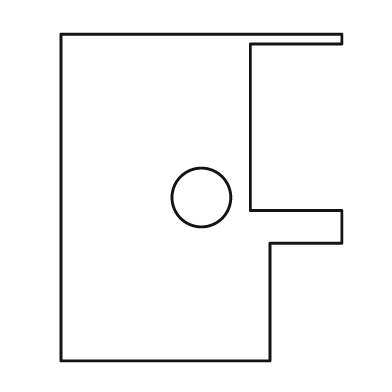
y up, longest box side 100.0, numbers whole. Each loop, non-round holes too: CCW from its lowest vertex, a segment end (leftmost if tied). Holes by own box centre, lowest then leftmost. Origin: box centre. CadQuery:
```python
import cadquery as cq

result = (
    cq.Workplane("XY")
    .moveTo(-43.0, -50.0)
    .lineTo(21.0, -50.0)
    .lineTo(21.0, -14.0)
    .lineTo(43.0, -14.0)
    .lineTo(43.0, -4.0)
    .lineTo(15.0, -4.0)
    .lineTo(15.0, 47.0)
    .lineTo(43.0, 47.0)
    .lineTo(43.0, 50.0)
    .lineTo(-43.0, 50.0)
    .close()
    .moveTo(0.0, 0.0)
    .circle(9.0)
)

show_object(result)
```